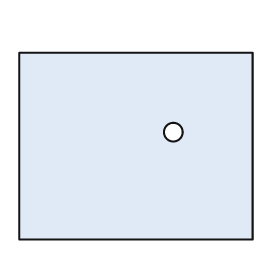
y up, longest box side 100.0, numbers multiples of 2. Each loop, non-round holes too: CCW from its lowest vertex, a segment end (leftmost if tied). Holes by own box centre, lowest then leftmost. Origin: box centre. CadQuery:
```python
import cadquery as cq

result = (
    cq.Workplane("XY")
    .moveTo(-50.0, -40.0)
    .lineTo(50.0, -40.0)
    .lineTo(50.0, 40.0)
    .lineTo(-50.0, 40.0)
    .close()
    .moveTo(16.0, 6.0)
    .circle(4.0)
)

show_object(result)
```